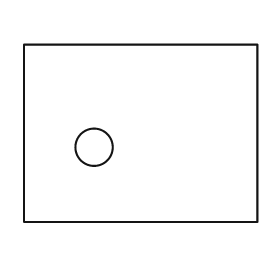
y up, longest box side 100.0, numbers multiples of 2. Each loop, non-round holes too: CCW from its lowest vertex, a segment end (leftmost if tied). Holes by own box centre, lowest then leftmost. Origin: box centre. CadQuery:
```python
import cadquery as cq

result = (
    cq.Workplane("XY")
    .moveTo(-50.0, -38.0)
    .lineTo(50.0, -38.0)
    .lineTo(50.0, 38.0)
    .lineTo(-50.0, 38.0)
    .close()
    .moveTo(-20.0, -6.0)
    .circle(8.0)
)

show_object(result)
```